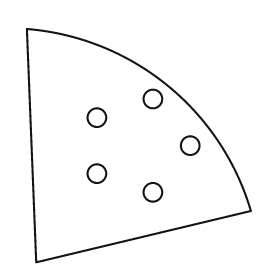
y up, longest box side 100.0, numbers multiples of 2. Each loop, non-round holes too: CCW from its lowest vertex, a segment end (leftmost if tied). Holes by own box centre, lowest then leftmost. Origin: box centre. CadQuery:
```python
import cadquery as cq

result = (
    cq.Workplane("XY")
    .moveTo(-44.0, -50.0)
    .lineTo(48.0, -28.0)
    .threePointArc((12.0, 26.0), (-48.0, 50.0))
    .close()
    .moveTo(6.0, -20.0)
    .circle(4.0)
    .moveTo(-18.0, -12.0)
    .circle(4.0)
    .moveTo(22.0, 0.0)
    .circle(4.0)
    .moveTo(-18.0, 12.0)
    .circle(4.0)
    .moveTo(6.0, 20.0)
    .circle(4.0)
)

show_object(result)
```